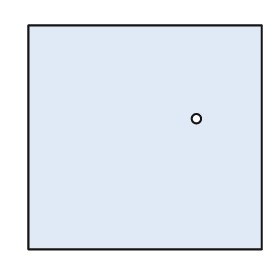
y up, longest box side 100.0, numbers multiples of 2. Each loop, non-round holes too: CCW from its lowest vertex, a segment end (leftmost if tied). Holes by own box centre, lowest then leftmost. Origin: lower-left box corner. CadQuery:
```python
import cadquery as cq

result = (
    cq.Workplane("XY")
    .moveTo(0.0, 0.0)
    .lineTo(100.0, 0.0)
    .lineTo(100.0, 96.0)
    .lineTo(0.0, 96.0)
    .close()
    .moveTo(72.0, 56.0)
    .circle(2.0)
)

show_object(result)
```